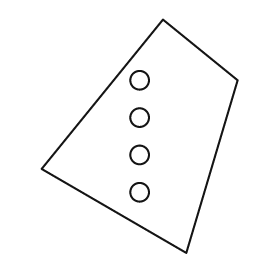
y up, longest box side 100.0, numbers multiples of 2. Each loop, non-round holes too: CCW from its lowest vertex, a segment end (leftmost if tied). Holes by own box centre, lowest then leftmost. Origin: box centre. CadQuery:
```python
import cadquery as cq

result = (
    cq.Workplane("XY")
    .moveTo(20.0, -50.0)
    .lineTo(42.0, 24.0)
    .lineTo(10.0, 50.0)
    .lineTo(-42.0, -14.0)
    .close()
    .moveTo(0.0, -24.0)
    .circle(4.0)
    .moveTo(0.0, -8.0)
    .circle(4.0)
    .moveTo(0.0, 8.0)
    .circle(4.0)
    .moveTo(0.0, 24.0)
    .circle(4.0)
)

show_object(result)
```